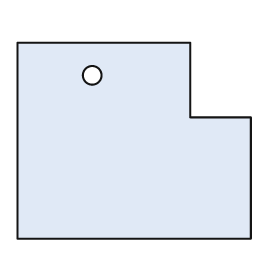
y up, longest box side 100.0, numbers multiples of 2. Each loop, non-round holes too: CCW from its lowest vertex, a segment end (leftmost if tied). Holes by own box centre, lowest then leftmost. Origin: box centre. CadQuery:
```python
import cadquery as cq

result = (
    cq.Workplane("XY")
    .moveTo(-50.0, -42.0)
    .lineTo(50.0, -42.0)
    .lineTo(50.0, 10.0)
    .lineTo(24.0, 10.0)
    .lineTo(24.0, 42.0)
    .lineTo(-50.0, 42.0)
    .close()
    .moveTo(-18.0, 28.0)
    .circle(4.0)
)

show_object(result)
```